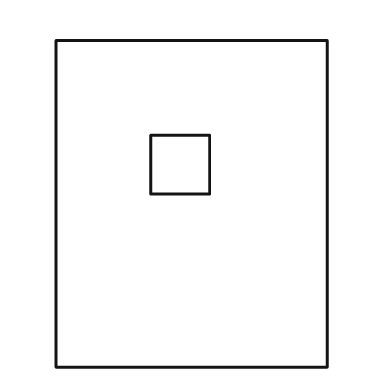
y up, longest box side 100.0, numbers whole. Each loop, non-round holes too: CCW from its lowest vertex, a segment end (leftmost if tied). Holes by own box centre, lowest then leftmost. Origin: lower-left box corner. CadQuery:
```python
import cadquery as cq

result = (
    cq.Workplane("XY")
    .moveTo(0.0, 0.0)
    .lineTo(83.0, 0.0)
    .lineTo(83.0, 100.0)
    .lineTo(0.0, 100.0)
    .close()
    .moveTo(29.0, 53.0)
    .lineTo(47.0, 53.0)
    .lineTo(47.0, 71.0)
    .lineTo(29.0, 71.0)
    .close()
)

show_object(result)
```